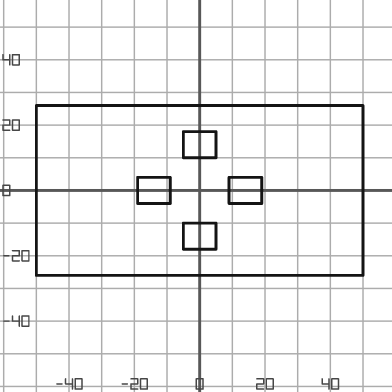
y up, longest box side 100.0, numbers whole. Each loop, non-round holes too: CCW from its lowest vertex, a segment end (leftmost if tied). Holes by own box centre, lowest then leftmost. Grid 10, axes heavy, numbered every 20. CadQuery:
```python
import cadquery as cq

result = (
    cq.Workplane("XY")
    .moveTo(-50.0, -26.0)
    .lineTo(50.0, -26.0)
    .lineTo(50.0, 26.0)
    .lineTo(-50.0, 26.0)
    .close()
    .moveTo(-5.0, -18.0)
    .lineTo(5.0, -18.0)
    .lineTo(5.0, -10.0)
    .lineTo(-5.0, -10.0)
    .close()
    .moveTo(-19.0, -4.0)
    .lineTo(-9.0, -4.0)
    .lineTo(-9.0, 4.0)
    .lineTo(-19.0, 4.0)
    .close()
    .moveTo(9.0, -4.0)
    .lineTo(19.0, -4.0)
    .lineTo(19.0, 4.0)
    .lineTo(9.0, 4.0)
    .close()
    .moveTo(-5.0, 10.0)
    .lineTo(5.0, 10.0)
    .lineTo(5.0, 18.0)
    .lineTo(-5.0, 18.0)
    .close()
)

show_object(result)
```